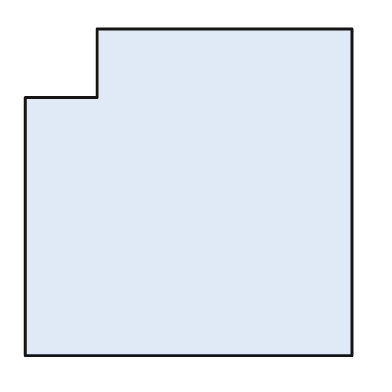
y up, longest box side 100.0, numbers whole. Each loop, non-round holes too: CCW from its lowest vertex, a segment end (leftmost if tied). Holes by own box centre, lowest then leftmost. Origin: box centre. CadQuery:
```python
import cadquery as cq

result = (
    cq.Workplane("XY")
    .moveTo(-50.0, -50.0)
    .lineTo(50.0, -50.0)
    .lineTo(50.0, 50.0)
    .lineTo(-28.0, 50.0)
    .lineTo(-28.0, 29.0)
    .lineTo(-50.0, 29.0)
    .close()
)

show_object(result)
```